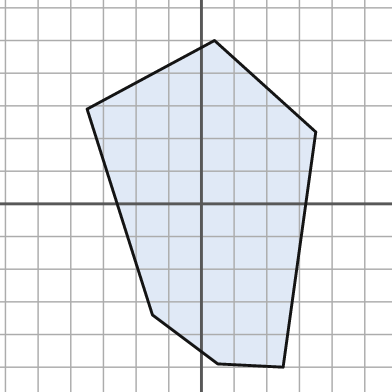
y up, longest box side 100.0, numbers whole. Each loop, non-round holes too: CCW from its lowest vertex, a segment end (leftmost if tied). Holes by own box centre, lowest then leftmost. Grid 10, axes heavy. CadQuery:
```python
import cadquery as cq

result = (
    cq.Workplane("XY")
    .moveTo(25.0, -50.0)
    .lineTo(35.0, 22.0)
    .lineTo(4.0, 50.0)
    .lineTo(-35.0, 29.0)
    .lineTo(-15.0, -34.0)
    .lineTo(5.0, -49.0)
    .close()
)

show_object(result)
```